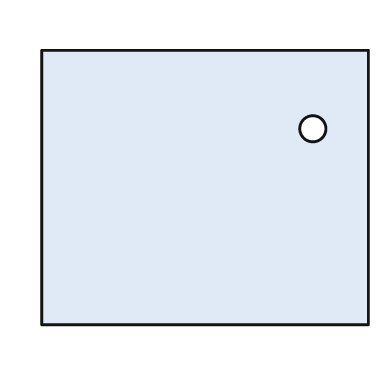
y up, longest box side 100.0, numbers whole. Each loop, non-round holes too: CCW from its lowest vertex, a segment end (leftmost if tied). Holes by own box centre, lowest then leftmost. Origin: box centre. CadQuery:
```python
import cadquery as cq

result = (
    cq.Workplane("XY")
    .moveTo(-50.0, -42.0)
    .lineTo(50.0, -42.0)
    .lineTo(50.0, 42.0)
    .lineTo(-50.0, 42.0)
    .close()
    .moveTo(33.0, 18.0)
    .circle(4.0)
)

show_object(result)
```